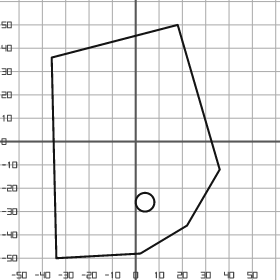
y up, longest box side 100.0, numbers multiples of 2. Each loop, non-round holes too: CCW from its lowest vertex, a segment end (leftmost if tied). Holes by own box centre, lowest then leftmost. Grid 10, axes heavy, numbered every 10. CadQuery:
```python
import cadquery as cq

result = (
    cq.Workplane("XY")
    .moveTo(-34.0, -50.0)
    .lineTo(2.0, -48.0)
    .lineTo(22.0, -36.0)
    .lineTo(36.0, -12.0)
    .lineTo(18.0, 50.0)
    .lineTo(-36.0, 36.0)
    .close()
    .moveTo(4.0, -26.0)
    .circle(4.0)
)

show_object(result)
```